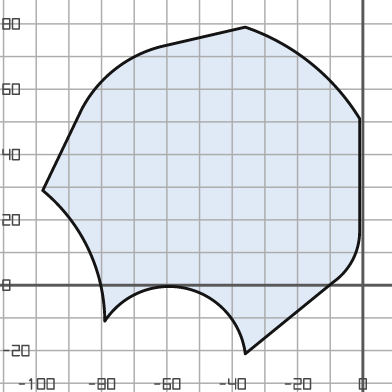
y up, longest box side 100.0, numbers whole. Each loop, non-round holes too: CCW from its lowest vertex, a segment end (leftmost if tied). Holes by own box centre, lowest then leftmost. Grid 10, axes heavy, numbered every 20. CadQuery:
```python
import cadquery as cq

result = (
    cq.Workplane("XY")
    .moveTo(-36.0, -21.0)
    .lineTo(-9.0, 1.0)
    .threePointArc((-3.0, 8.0), (-1.0, 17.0))
    .lineTo(-1.0, 51.0)
    .threePointArc((-16.0, 68.0), (-36.0, 79.0))
    .lineTo(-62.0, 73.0)
    .threePointArc((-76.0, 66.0), (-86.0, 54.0))
    .lineTo(-98.0, 29.0)
    .threePointArc((-84.0, 11.0), (-79.0, -11.0))
    .threePointArc((-54.0, -1.0), (-36.0, -21.0))
    .close()
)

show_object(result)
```